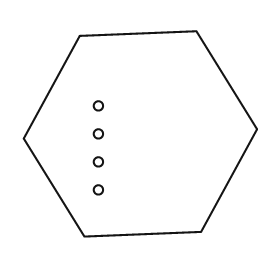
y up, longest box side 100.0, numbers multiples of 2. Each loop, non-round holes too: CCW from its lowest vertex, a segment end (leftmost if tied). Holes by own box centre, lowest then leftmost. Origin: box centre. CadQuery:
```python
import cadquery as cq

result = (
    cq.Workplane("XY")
    .moveTo(-24.0, -44.0)
    .lineTo(26.0, -42.0)
    .lineTo(50.0, 2.0)
    .lineTo(24.0, 44.0)
    .lineTo(-26.0, 42.0)
    .lineTo(-50.0, -2.0)
    .close()
    .moveTo(-18.0, -24.0)
    .circle(2.0)
    .moveTo(-18.0, -12.0)
    .circle(2.0)
    .moveTo(-18.0, 0.0)
    .circle(2.0)
    .moveTo(-18.0, 12.0)
    .circle(2.0)
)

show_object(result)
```